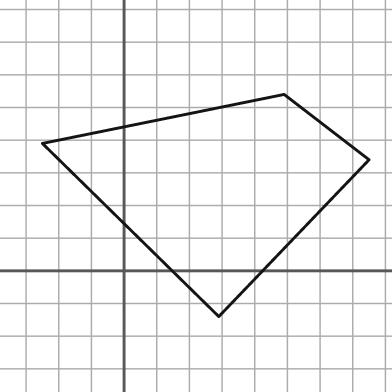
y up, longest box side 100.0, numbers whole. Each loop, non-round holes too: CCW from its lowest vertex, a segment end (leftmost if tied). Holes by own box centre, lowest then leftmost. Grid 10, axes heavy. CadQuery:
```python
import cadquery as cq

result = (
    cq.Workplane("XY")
    .moveTo(29.0, -14.0)
    .lineTo(75.0, 34.0)
    .lineTo(49.0, 54.0)
    .lineTo(-25.0, 39.0)
    .close()
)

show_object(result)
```